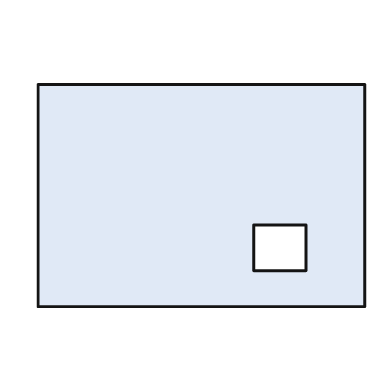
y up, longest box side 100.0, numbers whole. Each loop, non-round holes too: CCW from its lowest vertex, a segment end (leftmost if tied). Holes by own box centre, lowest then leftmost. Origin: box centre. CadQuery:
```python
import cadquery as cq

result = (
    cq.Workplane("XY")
    .moveTo(-50.0, -34.0)
    .lineTo(50.0, -34.0)
    .lineTo(50.0, 34.0)
    .lineTo(-50.0, 34.0)
    .close()
    .moveTo(16.0, -23.0)
    .lineTo(32.0, -23.0)
    .lineTo(32.0, -9.0)
    .lineTo(16.0, -9.0)
    .close()
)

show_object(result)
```